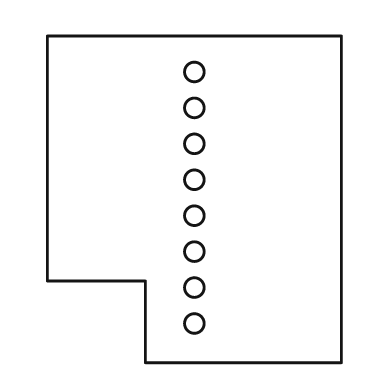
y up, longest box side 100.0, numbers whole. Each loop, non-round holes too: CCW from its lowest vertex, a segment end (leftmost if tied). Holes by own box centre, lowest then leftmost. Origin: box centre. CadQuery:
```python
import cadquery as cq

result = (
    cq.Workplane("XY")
    .moveTo(-15.0, -50.0)
    .lineTo(45.0, -50.0)
    .lineTo(45.0, 50.0)
    .lineTo(-45.0, 50.0)
    .lineTo(-45.0, -25.0)
    .lineTo(-15.0, -25.0)
    .close()
    .moveTo(0.0, -38.0)
    .circle(3.0)
    .moveTo(0.0, -27.0)
    .circle(3.0)
    .moveTo(0.0, -16.0)
    .circle(3.0)
    .moveTo(0.0, -5.0)
    .circle(3.0)
    .moveTo(0.0, 6.0)
    .circle(3.0)
    .moveTo(0.0, 17.0)
    .circle(3.0)
    .moveTo(0.0, 28.0)
    .circle(3.0)
    .moveTo(0.0, 39.0)
    .circle(3.0)
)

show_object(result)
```